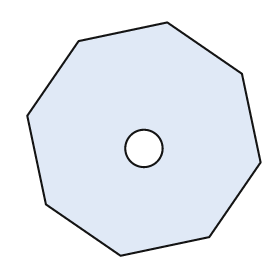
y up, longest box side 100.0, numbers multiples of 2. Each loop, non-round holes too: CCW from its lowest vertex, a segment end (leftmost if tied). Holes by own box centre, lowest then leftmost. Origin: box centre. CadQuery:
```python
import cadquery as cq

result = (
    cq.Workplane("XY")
    .moveTo(-10.0, -50.0)
    .lineTo(28.0, -42.0)
    .lineTo(50.0, -10.0)
    .lineTo(42.0, 28.0)
    .lineTo(10.0, 50.0)
    .lineTo(-28.0, 42.0)
    .lineTo(-50.0, 10.0)
    .lineTo(-42.0, -28.0)
    .close()
    .moveTo(0.0, -4.0)
    .circle(8.0)
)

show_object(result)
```